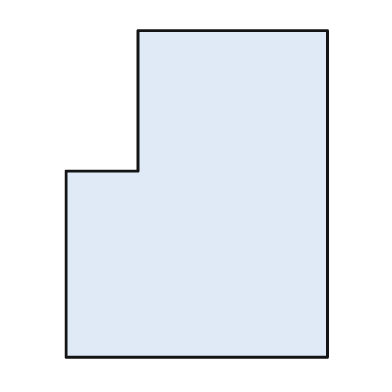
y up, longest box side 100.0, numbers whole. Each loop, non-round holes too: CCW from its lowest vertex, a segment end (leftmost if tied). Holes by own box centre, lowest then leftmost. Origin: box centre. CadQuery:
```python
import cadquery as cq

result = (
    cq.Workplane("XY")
    .moveTo(-40.0, -50.0)
    .lineTo(40.0, -50.0)
    .lineTo(40.0, 50.0)
    .lineTo(-18.0, 50.0)
    .lineTo(-18.0, 7.0)
    .lineTo(-40.0, 7.0)
    .close()
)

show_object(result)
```